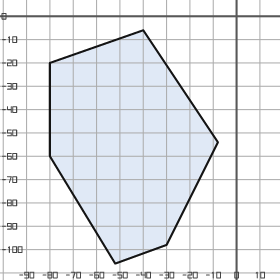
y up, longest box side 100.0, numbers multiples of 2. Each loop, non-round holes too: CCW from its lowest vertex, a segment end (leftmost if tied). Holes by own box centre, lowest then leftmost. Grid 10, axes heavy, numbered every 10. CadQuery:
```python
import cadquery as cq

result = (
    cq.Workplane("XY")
    .moveTo(-52.0, -106.0)
    .lineTo(-30.0, -98.0)
    .lineTo(-8.0, -54.0)
    .lineTo(-40.0, -6.0)
    .lineTo(-80.0, -20.0)
    .lineTo(-80.0, -60.0)
    .close()
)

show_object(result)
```